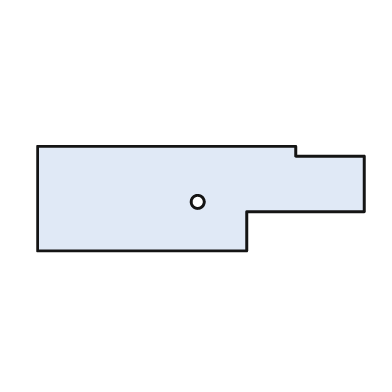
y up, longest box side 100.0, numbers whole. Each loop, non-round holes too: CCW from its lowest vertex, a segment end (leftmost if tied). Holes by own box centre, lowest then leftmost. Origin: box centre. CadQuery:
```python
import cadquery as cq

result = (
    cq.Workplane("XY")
    .moveTo(-50.0, -16.0)
    .lineTo(14.0, -16.0)
    .lineTo(14.0, -4.0)
    .lineTo(50.0, -4.0)
    .lineTo(50.0, 13.0)
    .lineTo(29.0, 13.0)
    .lineTo(29.0, 16.0)
    .lineTo(-50.0, 16.0)
    .close()
    .moveTo(-1.0, -1.0)
    .circle(2.0)
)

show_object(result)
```